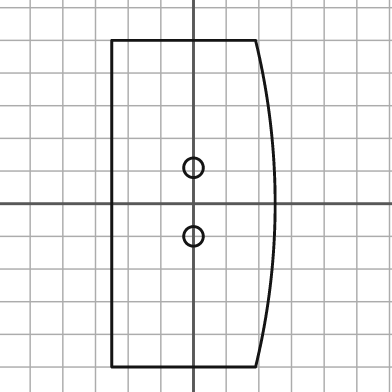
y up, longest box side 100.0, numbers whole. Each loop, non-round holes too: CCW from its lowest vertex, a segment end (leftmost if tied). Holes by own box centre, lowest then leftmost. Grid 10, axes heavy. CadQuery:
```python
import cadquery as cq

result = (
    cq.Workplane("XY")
    .moveTo(-25.0, -50.0)
    .lineTo(19.0, -50.0)
    .threePointArc((25.0, 0.0), (19.0, 50.0))
    .lineTo(-25.0, 50.0)
    .close()
    .moveTo(0.0, -10.0)
    .circle(3.0)
    .moveTo(0.0, 11.0)
    .circle(3.0)
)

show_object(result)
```